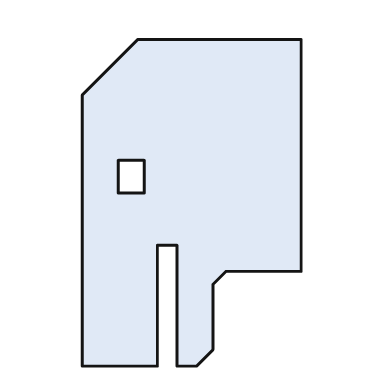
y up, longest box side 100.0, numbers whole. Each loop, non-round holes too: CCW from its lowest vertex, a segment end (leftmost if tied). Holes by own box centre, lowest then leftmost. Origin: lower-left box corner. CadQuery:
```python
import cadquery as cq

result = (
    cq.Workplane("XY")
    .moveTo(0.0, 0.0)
    .lineTo(23.0, 0.0)
    .lineTo(23.0, 37.0)
    .lineTo(29.0, 37.0)
    .lineTo(29.0, 0.0)
    .lineTo(35.0, 0.0)
    .lineTo(40.0, 5.0)
    .lineTo(40.0, 25.0)
    .lineTo(44.0, 29.0)
    .lineTo(67.0, 29.0)
    .lineTo(67.0, 100.0)
    .lineTo(17.0, 100.0)
    .lineTo(0.0, 83.0)
    .close()
    .moveTo(11.0, 53.0)
    .lineTo(19.0, 53.0)
    .lineTo(19.0, 63.0)
    .lineTo(11.0, 63.0)
    .close()
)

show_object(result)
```